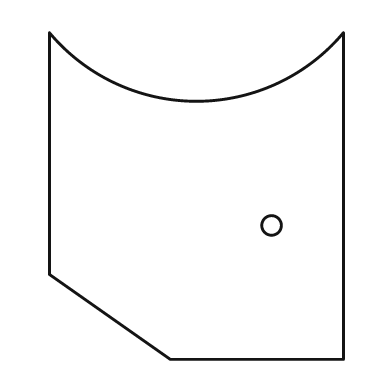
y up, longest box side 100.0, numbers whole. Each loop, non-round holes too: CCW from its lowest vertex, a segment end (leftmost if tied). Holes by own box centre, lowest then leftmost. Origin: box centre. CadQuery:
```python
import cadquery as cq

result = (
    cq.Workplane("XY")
    .moveTo(-8.0, -50.0)
    .lineTo(45.0, -50.0)
    .lineTo(45.0, 50.0)
    .threePointArc((0.0, 29.0), (-45.0, 50.0))
    .lineTo(-45.0, -24.0)
    .close()
    .moveTo(23.0, -9.0)
    .circle(3.0)
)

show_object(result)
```